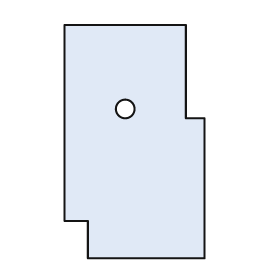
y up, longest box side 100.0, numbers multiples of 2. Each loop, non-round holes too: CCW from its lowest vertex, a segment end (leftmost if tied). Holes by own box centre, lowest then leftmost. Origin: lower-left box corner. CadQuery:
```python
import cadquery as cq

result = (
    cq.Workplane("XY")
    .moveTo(10.0, 0.0)
    .lineTo(60.0, 0.0)
    .lineTo(60.0, 60.0)
    .lineTo(52.0, 60.0)
    .lineTo(52.0, 100.0)
    .lineTo(0.0, 100.0)
    .lineTo(0.0, 16.0)
    .lineTo(10.0, 16.0)
    .close()
    .moveTo(26.0, 64.0)
    .circle(4.0)
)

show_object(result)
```